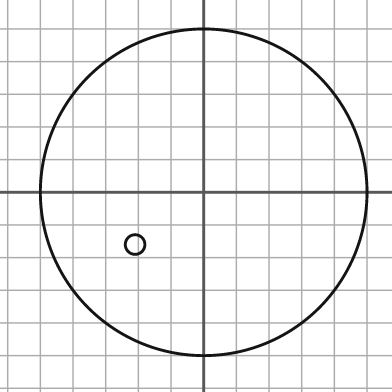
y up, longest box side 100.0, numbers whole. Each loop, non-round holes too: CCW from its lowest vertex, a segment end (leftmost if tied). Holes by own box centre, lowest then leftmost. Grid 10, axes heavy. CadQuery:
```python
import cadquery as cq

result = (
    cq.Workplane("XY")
    .moveTo(0.0, 0.0)
    .circle(50.0)
    .moveTo(-21.0, -16.0)
    .circle(3.0)
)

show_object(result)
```